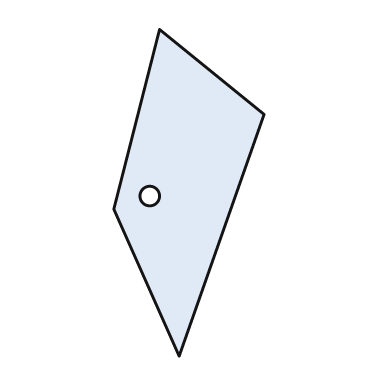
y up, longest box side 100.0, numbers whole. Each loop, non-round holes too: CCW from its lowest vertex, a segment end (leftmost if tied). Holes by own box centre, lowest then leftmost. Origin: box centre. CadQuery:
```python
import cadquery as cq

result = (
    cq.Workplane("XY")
    .moveTo(-3.0, -50.0)
    .lineTo(23.0, 24.0)
    .lineTo(-9.0, 50.0)
    .lineTo(-23.0, -5.0)
    .close()
    .moveTo(-12.0, -1.0)
    .circle(3.0)
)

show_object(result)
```